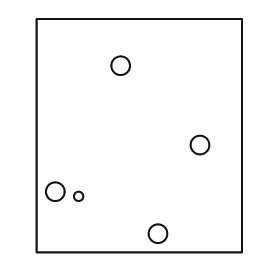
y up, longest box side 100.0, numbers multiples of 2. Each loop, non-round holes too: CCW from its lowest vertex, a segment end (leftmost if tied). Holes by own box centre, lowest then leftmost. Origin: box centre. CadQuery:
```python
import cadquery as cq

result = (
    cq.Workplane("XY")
    .moveTo(-44.0, -50.0)
    .lineTo(44.0, -50.0)
    .lineTo(44.0, 50.0)
    .lineTo(-44.0, 50.0)
    .close()
    .moveTo(8.0, -42.0)
    .circle(4.0)
    .moveTo(-26.0, -26.0)
    .circle(2.0)
    .moveTo(-36.0, -24.0)
    .circle(4.0)
    .moveTo(26.0, -4.0)
    .circle(4.0)
    .moveTo(-8.0, 30.0)
    .circle(4.0)
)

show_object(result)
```